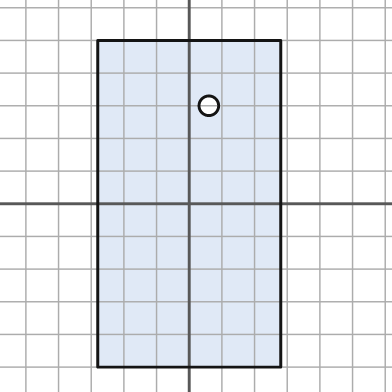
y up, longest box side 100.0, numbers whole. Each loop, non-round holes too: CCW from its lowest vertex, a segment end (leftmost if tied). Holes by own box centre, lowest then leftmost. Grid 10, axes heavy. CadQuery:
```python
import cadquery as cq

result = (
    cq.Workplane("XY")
    .moveTo(-28.0, -50.0)
    .lineTo(28.0, -50.0)
    .lineTo(28.0, 50.0)
    .lineTo(-28.0, 50.0)
    .close()
    .moveTo(6.0, 30.0)
    .circle(3.0)
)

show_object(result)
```